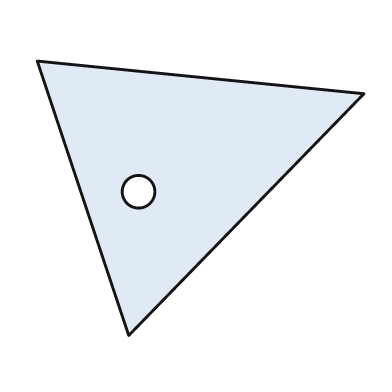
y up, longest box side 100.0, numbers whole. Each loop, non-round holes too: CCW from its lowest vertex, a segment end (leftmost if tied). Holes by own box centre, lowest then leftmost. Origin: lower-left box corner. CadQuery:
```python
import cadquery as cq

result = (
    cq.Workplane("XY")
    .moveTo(28.0, 0.0)
    .lineTo(100.0, 74.0)
    .lineTo(0.0, 84.0)
    .close()
    .moveTo(31.0, 44.0)
    .circle(5.0)
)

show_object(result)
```